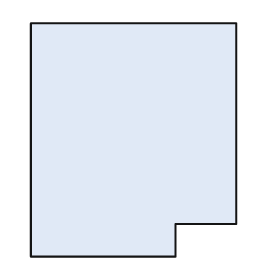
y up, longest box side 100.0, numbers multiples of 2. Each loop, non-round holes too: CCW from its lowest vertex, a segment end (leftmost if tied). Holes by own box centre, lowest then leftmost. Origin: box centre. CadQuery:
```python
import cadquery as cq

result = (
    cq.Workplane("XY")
    .moveTo(-44.0, -50.0)
    .lineTo(18.0, -50.0)
    .lineTo(18.0, -36.0)
    .lineTo(44.0, -36.0)
    .lineTo(44.0, 50.0)
    .lineTo(-44.0, 50.0)
    .close()
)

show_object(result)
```